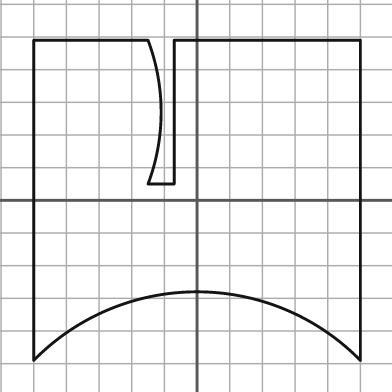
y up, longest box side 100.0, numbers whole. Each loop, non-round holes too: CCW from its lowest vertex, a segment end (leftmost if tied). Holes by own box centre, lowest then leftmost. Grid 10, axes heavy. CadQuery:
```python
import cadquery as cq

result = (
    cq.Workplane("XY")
    .moveTo(-50.0, -49.0)
    .threePointArc((0.0, -28.0), (50.0, -49.0))
    .lineTo(50.0, 49.0)
    .lineTo(-7.0, 49.0)
    .lineTo(-7.0, 5.0)
    .lineTo(-15.0, 5.0)
    .threePointArc((-11.0, 27.0), (-15.0, 49.0))
    .lineTo(-50.0, 49.0)
    .close()
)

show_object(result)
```